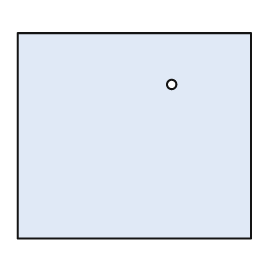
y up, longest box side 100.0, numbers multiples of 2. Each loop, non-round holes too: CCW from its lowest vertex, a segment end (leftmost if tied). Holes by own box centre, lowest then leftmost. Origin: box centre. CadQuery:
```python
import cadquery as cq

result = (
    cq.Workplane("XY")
    .moveTo(-50.0, -44.0)
    .lineTo(50.0, -44.0)
    .lineTo(50.0, 44.0)
    .lineTo(-50.0, 44.0)
    .close()
    .moveTo(16.0, 22.0)
    .circle(2.0)
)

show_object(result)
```